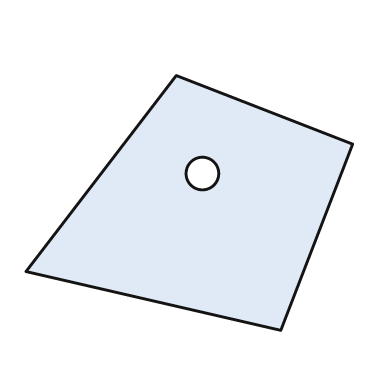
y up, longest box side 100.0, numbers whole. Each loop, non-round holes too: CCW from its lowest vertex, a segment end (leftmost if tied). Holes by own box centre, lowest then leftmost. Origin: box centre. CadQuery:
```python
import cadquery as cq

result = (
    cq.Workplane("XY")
    .moveTo(28.0, -39.0)
    .lineTo(50.0, 18.0)
    .lineTo(-4.0, 39.0)
    .lineTo(-50.0, -21.0)
    .close()
    .moveTo(4.0, 9.0)
    .circle(5.0)
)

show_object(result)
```